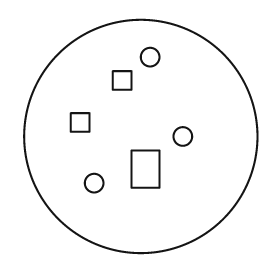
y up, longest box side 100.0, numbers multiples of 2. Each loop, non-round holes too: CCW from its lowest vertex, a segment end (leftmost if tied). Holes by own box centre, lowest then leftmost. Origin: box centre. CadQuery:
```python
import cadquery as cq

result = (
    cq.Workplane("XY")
    .moveTo(0.0, 0.0)
    .circle(50.0)
    .moveTo(-20.0, -20.0)
    .circle(4.0)
    .moveTo(-4.0, -22.0)
    .lineTo(8.0, -22.0)
    .lineTo(8.0, -6.0)
    .lineTo(-4.0, -6.0)
    .close()
    .moveTo(18.0, 0.0)
    .circle(4.0)
    .moveTo(-30.0, 2.0)
    .lineTo(-22.0, 2.0)
    .lineTo(-22.0, 10.0)
    .lineTo(-30.0, 10.0)
    .close()
    .moveTo(-12.0, 20.0)
    .lineTo(-4.0, 20.0)
    .lineTo(-4.0, 28.0)
    .lineTo(-12.0, 28.0)
    .close()
    .moveTo(4.0, 34.0)
    .circle(4.0)
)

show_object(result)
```